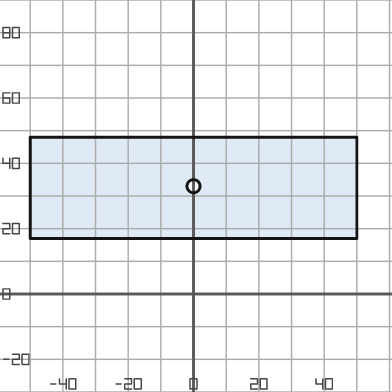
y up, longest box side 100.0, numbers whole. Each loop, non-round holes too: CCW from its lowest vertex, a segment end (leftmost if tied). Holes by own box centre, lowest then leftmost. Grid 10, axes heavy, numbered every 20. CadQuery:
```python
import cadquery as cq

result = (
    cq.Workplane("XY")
    .moveTo(-50.0, 17.0)
    .lineTo(50.0, 17.0)
    .lineTo(50.0, 48.0)
    .lineTo(-50.0, 48.0)
    .close()
    .moveTo(0.0, 33.0)
    .circle(2.0)
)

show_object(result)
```